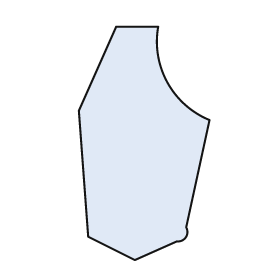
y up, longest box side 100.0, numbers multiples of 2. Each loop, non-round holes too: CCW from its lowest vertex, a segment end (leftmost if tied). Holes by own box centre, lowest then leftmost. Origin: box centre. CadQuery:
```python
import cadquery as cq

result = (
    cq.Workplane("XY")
    .moveTo(-4.0, -50.0)
    .lineTo(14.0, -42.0)
    .threePointArc((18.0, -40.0), (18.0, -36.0))
    .lineTo(28.0, 10.0)
    .threePointArc((10.0, 26.0), (6.0, 50.0))
    .lineTo(-12.0, 50.0)
    .lineTo(-28.0, 14.0)
    .lineTo(-24.0, -40.0)
    .close()
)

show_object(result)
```